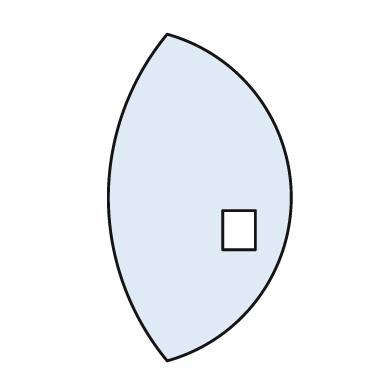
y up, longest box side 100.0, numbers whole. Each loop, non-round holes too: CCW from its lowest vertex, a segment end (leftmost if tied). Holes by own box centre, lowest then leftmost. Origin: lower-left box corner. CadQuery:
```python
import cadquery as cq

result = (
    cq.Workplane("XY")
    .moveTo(18.0, 0.0)
    .threePointArc((56.0, 50.0), (18.0, 100.0))
    .threePointArc((0.0, 50.0), (18.0, 0.0))
    .close()
    .moveTo(35.0, 34.0)
    .lineTo(45.0, 34.0)
    .lineTo(45.0, 46.0)
    .lineTo(35.0, 46.0)
    .close()
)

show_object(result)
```